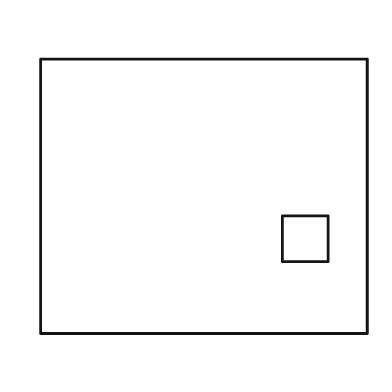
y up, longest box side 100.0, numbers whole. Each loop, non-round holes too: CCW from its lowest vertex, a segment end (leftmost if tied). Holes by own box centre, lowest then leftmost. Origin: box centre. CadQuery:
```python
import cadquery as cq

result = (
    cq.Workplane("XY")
    .moveTo(-50.0, -42.0)
    .lineTo(50.0, -42.0)
    .lineTo(50.0, 42.0)
    .lineTo(-50.0, 42.0)
    .close()
    .moveTo(24.0, -20.0)
    .lineTo(38.0, -20.0)
    .lineTo(38.0, -6.0)
    .lineTo(24.0, -6.0)
    .close()
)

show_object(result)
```